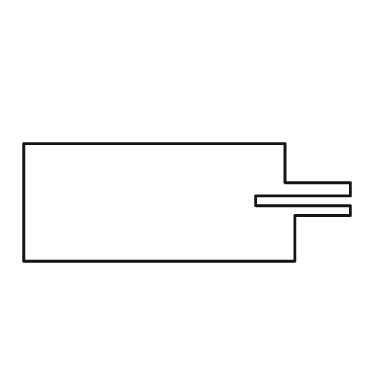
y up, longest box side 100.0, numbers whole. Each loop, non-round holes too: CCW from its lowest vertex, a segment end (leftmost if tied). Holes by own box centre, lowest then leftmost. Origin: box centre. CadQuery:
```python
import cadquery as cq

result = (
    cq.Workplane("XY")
    .moveTo(-50.0, -18.0)
    .lineTo(33.0, -18.0)
    .lineTo(33.0, -4.0)
    .lineTo(50.0, -4.0)
    .lineTo(50.0, -1.0)
    .lineTo(21.0, -1.0)
    .lineTo(21.0, 2.0)
    .lineTo(50.0, 2.0)
    .lineTo(50.0, 6.0)
    .lineTo(30.0, 6.0)
    .lineTo(30.0, 18.0)
    .lineTo(-50.0, 18.0)
    .close()
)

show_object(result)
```